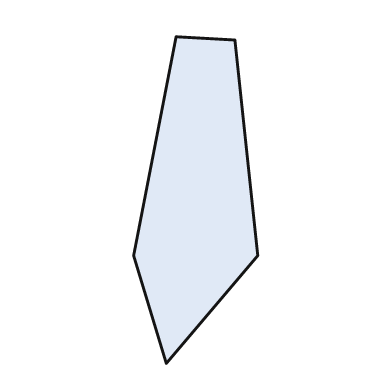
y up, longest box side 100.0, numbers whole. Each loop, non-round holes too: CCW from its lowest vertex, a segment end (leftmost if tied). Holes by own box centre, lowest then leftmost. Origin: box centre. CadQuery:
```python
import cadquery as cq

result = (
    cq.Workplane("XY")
    .moveTo(-9.0, -50.0)
    .lineTo(19.0, -17.0)
    .lineTo(12.0, 49.0)
    .lineTo(-6.0, 50.0)
    .lineTo(-19.0, -17.0)
    .close()
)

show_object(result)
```